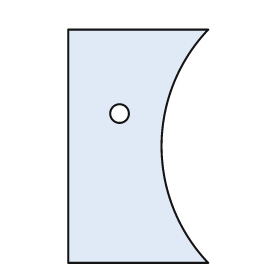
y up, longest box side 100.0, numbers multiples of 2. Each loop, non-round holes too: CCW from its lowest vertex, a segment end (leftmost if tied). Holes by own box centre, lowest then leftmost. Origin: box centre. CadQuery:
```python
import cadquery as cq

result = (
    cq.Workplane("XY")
    .moveTo(-30.0, -50.0)
    .lineTo(30.0, -50.0)
    .threePointArc((10.0, 0.0), (30.0, 50.0))
    .lineTo(-30.0, 50.0)
    .close()
    .moveTo(-8.0, 14.0)
    .circle(4.0)
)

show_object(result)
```